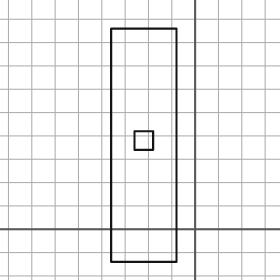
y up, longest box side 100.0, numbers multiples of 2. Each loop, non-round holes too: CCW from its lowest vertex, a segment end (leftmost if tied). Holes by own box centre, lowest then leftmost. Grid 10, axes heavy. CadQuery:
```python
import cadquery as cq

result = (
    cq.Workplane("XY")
    .moveTo(-36.0, -14.0)
    .lineTo(-8.0, -14.0)
    .lineTo(-8.0, 86.0)
    .lineTo(-36.0, 86.0)
    .close()
    .moveTo(-26.0, 34.0)
    .lineTo(-18.0, 34.0)
    .lineTo(-18.0, 42.0)
    .lineTo(-26.0, 42.0)
    .close()
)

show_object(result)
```